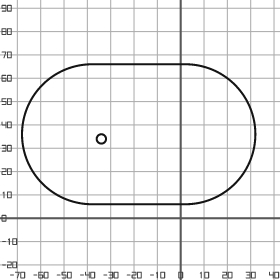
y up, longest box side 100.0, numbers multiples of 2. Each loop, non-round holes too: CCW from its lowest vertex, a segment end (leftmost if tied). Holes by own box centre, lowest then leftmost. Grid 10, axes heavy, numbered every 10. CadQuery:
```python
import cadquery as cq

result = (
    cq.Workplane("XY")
    .moveTo(-38.0, 6.0)
    .lineTo(2.0, 6.0)
    .threePointArc((32.0, 36.0), (2.0, 66.0))
    .lineTo(-38.0, 66.0)
    .threePointArc((-68.0, 36.0), (-38.0, 6.0))
    .close()
    .moveTo(-34.0, 34.0)
    .circle(2.0)
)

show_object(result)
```